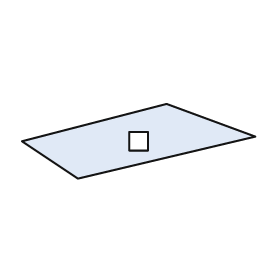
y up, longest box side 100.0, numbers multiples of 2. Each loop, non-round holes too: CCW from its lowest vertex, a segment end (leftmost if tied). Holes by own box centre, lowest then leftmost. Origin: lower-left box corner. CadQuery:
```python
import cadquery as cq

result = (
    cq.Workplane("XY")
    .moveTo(24.0, 0.0)
    .lineTo(100.0, 18.0)
    .lineTo(62.0, 32.0)
    .lineTo(0.0, 16.0)
    .close()
    .moveTo(46.0, 12.0)
    .lineTo(54.0, 12.0)
    .lineTo(54.0, 20.0)
    .lineTo(46.0, 20.0)
    .close()
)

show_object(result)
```